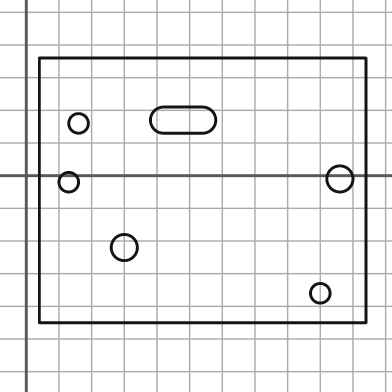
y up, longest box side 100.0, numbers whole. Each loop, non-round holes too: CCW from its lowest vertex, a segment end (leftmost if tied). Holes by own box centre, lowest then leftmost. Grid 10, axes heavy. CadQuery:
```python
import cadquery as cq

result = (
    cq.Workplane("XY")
    .moveTo(4.0, -45.0)
    .lineTo(104.0, -45.0)
    .lineTo(104.0, 36.0)
    .lineTo(4.0, 36.0)
    .close()
    .moveTo(90.0, -36.0)
    .circle(3.0)
    .moveTo(30.0, -22.0)
    .circle(4.0)
    .moveTo(13.0, -2.0)
    .circle(3.0)
    .moveTo(96.0, -1.0)
    .circle(4.0)
    .moveTo(16.0, 16.0)
    .circle(3.0)
    .moveTo(42.0, 13.0)
    .lineTo(54.0, 13.0)
    .threePointArc((58.0, 17.0), (54.0, 21.0))
    .lineTo(42.0, 21.0)
    .threePointArc((38.0, 17.0), (42.0, 13.0))
    .close()
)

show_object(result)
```